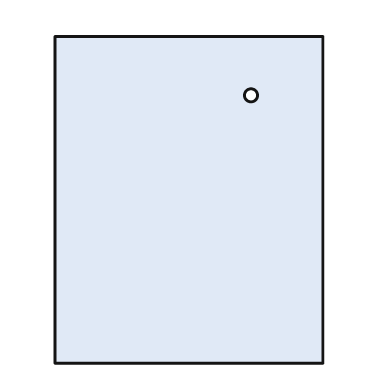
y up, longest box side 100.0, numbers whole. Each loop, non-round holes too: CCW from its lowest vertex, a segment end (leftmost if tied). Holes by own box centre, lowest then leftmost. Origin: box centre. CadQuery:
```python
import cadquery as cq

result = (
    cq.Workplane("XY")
    .moveTo(-41.0, -50.0)
    .lineTo(41.0, -50.0)
    .lineTo(41.0, 50.0)
    .lineTo(-41.0, 50.0)
    .close()
    .moveTo(19.0, 32.0)
    .circle(2.0)
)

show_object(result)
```